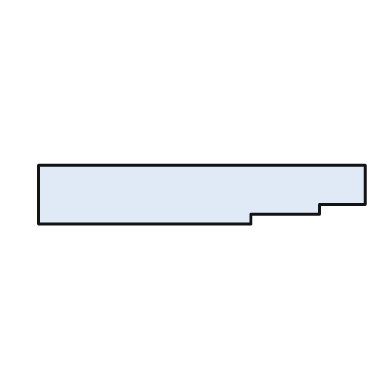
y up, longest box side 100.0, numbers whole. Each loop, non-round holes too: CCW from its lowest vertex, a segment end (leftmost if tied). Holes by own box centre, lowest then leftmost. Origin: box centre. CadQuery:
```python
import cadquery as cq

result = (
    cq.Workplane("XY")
    .moveTo(-50.0, -9.0)
    .lineTo(15.0, -9.0)
    .lineTo(15.0, -6.0)
    .lineTo(36.0, -6.0)
    .lineTo(36.0, -3.0)
    .lineTo(50.0, -3.0)
    .lineTo(50.0, 9.0)
    .lineTo(-50.0, 9.0)
    .close()
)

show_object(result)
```